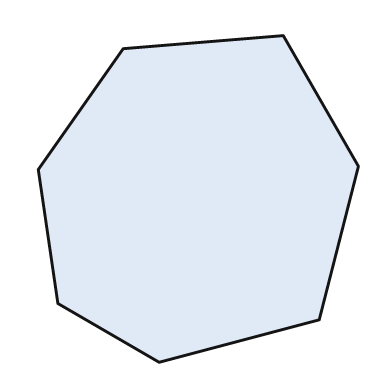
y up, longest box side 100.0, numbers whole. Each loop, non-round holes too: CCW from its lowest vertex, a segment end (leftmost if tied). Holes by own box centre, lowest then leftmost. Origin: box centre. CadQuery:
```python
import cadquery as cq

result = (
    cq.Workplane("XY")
    .moveTo(-12.0, -50.0)
    .lineTo(37.0, -37.0)
    .lineTo(49.0, 10.0)
    .lineTo(26.0, 50.0)
    .lineTo(-23.0, 46.0)
    .lineTo(-49.0, 9.0)
    .lineTo(-43.0, -32.0)
    .close()
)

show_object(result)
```